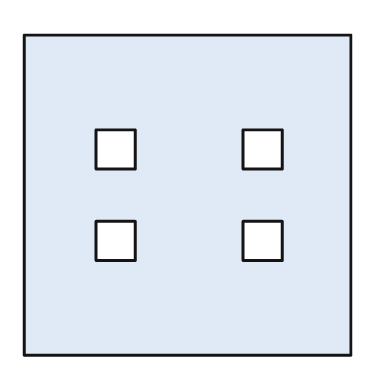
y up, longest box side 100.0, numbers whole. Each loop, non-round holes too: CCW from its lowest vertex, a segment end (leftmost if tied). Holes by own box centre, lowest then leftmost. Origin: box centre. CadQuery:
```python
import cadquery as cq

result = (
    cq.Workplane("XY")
    .moveTo(-50.0, -49.0)
    .lineTo(50.0, -49.0)
    .lineTo(50.0, 49.0)
    .lineTo(-50.0, 49.0)
    .close()
    .moveTo(-28.0, -20.0)
    .lineTo(-16.0, -20.0)
    .lineTo(-16.0, -8.0)
    .lineTo(-28.0, -8.0)
    .close()
    .moveTo(17.0, -20.0)
    .lineTo(29.0, -20.0)
    .lineTo(29.0, -8.0)
    .lineTo(17.0, -8.0)
    .close()
    .moveTo(-28.0, 8.0)
    .lineTo(-16.0, 8.0)
    .lineTo(-16.0, 20.0)
    .lineTo(-28.0, 20.0)
    .close()
    .moveTo(17.0, 8.0)
    .lineTo(29.0, 8.0)
    .lineTo(29.0, 20.0)
    .lineTo(17.0, 20.0)
    .close()
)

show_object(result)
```